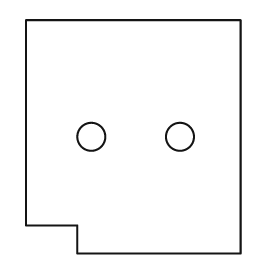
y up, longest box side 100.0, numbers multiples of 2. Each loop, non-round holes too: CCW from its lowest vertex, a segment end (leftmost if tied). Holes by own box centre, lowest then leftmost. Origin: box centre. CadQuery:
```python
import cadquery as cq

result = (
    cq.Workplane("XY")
    .moveTo(-24.0, -50.0)
    .lineTo(46.0, -50.0)
    .lineTo(46.0, 50.0)
    .lineTo(-46.0, 50.0)
    .lineTo(-46.0, -38.0)
    .lineTo(-24.0, -38.0)
    .close()
    .moveTo(-18.0, 0.0)
    .circle(6.0)
    .moveTo(20.0, 0.0)
    .circle(6.0)
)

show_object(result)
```